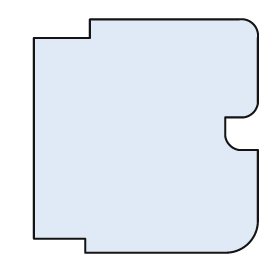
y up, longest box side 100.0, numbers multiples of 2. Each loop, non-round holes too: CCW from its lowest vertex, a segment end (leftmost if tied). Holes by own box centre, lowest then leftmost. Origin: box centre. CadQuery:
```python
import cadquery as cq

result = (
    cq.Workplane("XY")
    .moveTo(-26.0, -50.0)
    .lineTo(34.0, -50.0)
    .threePointArc((44.0, -46.0), (48.0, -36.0))
    .lineTo(48.0, -6.0)
    .lineTo(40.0, -6.0)
    .threePointArc((36.0, -4.0), (34.0, 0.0))
    .lineTo(34.0, 8.0)
    .lineTo(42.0, 8.0)
    .threePointArc((46.0, 10.0), (48.0, 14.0))
    .lineTo(48.0, 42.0)
    .threePointArc((46.0, 48.0), (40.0, 50.0))
    .lineTo(-24.0, 50.0)
    .lineTo(-24.0, 42.0)
    .lineTo(-48.0, 42.0)
    .lineTo(-48.0, -44.0)
    .lineTo(-26.0, -44.0)
    .close()
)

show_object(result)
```